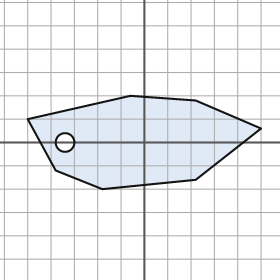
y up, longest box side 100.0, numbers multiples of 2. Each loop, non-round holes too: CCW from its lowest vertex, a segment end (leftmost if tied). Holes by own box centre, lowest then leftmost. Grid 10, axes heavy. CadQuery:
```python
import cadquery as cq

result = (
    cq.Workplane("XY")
    .moveTo(-18.0, -20.0)
    .lineTo(22.0, -16.0)
    .lineTo(50.0, 6.0)
    .lineTo(22.0, 18.0)
    .lineTo(-6.0, 20.0)
    .lineTo(-50.0, 10.0)
    .lineTo(-38.0, -12.0)
    .close()
    .moveTo(-34.0, 0.0)
    .circle(4.0)
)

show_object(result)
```